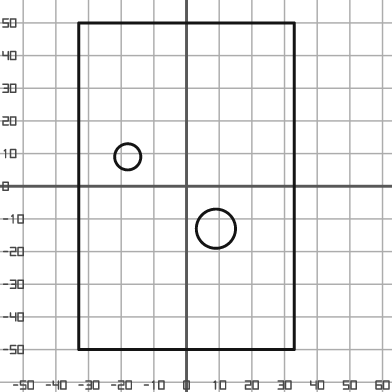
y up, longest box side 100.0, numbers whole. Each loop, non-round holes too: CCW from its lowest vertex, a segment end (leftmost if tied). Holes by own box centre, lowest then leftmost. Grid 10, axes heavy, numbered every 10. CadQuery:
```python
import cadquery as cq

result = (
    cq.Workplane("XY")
    .moveTo(-33.0, -50.0)
    .lineTo(33.0, -50.0)
    .lineTo(33.0, 50.0)
    .lineTo(-33.0, 50.0)
    .close()
    .moveTo(9.0, -13.0)
    .circle(6.0)
    .moveTo(-18.0, 9.0)
    .circle(4.0)
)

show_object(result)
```